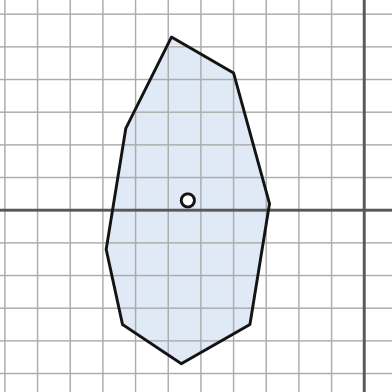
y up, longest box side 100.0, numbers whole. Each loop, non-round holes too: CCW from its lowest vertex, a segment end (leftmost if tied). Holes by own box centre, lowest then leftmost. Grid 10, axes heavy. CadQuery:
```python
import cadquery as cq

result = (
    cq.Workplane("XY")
    .moveTo(-56.0, -47.0)
    .lineTo(-35.0, -35.0)
    .lineTo(-29.0, 2.0)
    .lineTo(-40.0, 42.0)
    .lineTo(-59.0, 53.0)
    .lineTo(-73.0, 25.0)
    .lineTo(-79.0, -12.0)
    .lineTo(-74.0, -35.0)
    .close()
    .moveTo(-54.0, 3.0)
    .circle(2.0)
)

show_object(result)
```